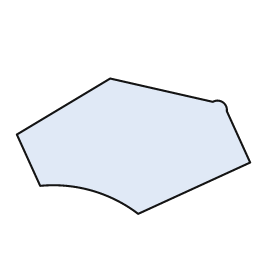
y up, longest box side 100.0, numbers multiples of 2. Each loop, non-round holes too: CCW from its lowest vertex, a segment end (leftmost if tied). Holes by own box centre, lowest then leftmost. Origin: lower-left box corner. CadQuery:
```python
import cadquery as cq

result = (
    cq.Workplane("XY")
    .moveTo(52.0, 0.0)
    .lineTo(100.0, 22.0)
    .lineTo(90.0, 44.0)
    .threePointArc((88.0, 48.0), (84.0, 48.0))
    .lineTo(40.0, 58.0)
    .lineTo(0.0, 34.0)
    .lineTo(10.0, 12.0)
    .threePointArc((32.0, 10.0), (52.0, 0.0))
    .close()
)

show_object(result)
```